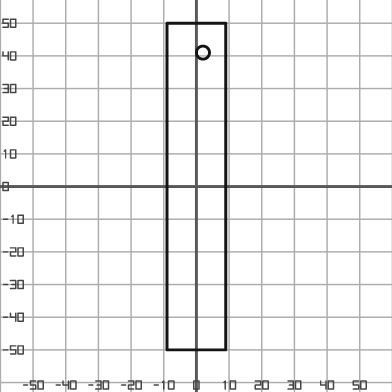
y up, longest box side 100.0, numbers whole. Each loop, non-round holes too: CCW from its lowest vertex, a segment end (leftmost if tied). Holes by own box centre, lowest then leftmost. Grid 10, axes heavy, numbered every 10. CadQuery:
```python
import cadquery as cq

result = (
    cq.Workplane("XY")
    .moveTo(-9.0, -50.0)
    .lineTo(9.0, -50.0)
    .lineTo(9.0, 50.0)
    .lineTo(-9.0, 50.0)
    .close()
    .moveTo(2.0, 41.0)
    .circle(2.0)
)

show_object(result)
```